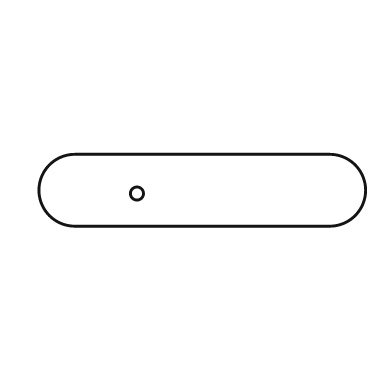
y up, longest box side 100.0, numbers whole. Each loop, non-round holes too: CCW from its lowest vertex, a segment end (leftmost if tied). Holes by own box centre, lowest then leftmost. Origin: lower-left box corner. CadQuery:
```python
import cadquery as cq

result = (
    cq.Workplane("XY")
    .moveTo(11.0, 0.0)
    .lineTo(89.0, 0.0)
    .threePointArc((100.0, 11.0), (89.0, 22.0))
    .lineTo(11.0, 22.0)
    .threePointArc((0.0, 11.0), (11.0, 0.0))
    .close()
    .moveTo(30.0, 10.0)
    .circle(2.0)
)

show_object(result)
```